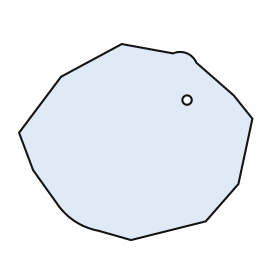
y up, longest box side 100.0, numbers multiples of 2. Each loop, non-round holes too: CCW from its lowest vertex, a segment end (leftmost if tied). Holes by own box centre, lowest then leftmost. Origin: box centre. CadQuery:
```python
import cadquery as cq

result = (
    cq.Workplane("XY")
    .moveTo(-2.0, -42.0)
    .lineTo(30.0, -34.0)
    .lineTo(44.0, -18.0)
    .lineTo(50.0, 10.0)
    .lineTo(42.0, 20.0)
    .lineTo(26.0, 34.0)
    .threePointArc((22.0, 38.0), (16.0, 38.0))
    .lineTo(-6.0, 42.0)
    .lineTo(-32.0, 28.0)
    .lineTo(-50.0, 4.0)
    .lineTo(-44.0, -12.0)
    .lineTo(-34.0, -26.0)
    .threePointArc((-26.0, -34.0), (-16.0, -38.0))
    .close()
    .moveTo(22.0, 18.0)
    .circle(2.0)
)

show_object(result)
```